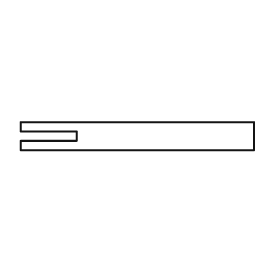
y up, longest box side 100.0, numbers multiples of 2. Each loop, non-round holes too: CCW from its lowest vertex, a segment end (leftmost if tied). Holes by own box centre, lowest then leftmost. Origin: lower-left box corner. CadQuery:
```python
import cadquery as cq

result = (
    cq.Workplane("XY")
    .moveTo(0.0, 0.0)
    .lineTo(100.0, 0.0)
    .lineTo(100.0, 12.0)
    .lineTo(0.0, 12.0)
    .lineTo(0.0, 8.0)
    .lineTo(24.0, 8.0)
    .lineTo(24.0, 4.0)
    .lineTo(0.0, 4.0)
    .close()
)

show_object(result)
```